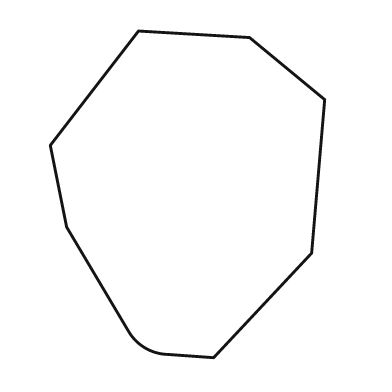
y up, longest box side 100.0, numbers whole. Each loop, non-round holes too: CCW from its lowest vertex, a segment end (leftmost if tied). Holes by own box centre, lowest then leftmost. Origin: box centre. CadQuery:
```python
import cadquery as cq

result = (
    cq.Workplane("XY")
    .moveTo(8.0, -50.0)
    .lineTo(38.0, -18.0)
    .lineTo(42.0, 29.0)
    .lineTo(19.0, 48.0)
    .lineTo(-15.0, 50.0)
    .lineTo(-42.0, 15.0)
    .lineTo(-37.0, -10.0)
    .lineTo(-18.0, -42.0)
    .threePointArc((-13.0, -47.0), (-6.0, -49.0))
    .close()
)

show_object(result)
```